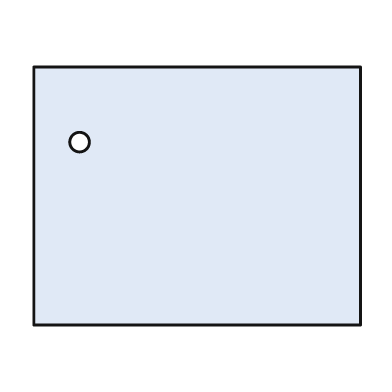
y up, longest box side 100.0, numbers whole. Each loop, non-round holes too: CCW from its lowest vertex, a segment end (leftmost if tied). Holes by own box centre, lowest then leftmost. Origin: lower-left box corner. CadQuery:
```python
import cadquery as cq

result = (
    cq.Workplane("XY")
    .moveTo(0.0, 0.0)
    .lineTo(100.0, 0.0)
    .lineTo(100.0, 79.0)
    .lineTo(0.0, 79.0)
    .close()
    .moveTo(14.0, 56.0)
    .circle(3.0)
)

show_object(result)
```